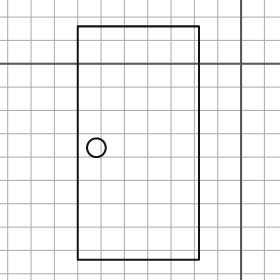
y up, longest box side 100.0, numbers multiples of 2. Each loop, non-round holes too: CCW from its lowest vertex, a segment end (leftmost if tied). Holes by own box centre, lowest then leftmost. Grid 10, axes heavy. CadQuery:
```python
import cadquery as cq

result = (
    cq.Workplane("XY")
    .moveTo(-70.0, -84.0)
    .lineTo(-18.0, -84.0)
    .lineTo(-18.0, 16.0)
    .lineTo(-70.0, 16.0)
    .close()
    .moveTo(-62.0, -36.0)
    .circle(4.0)
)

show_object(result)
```